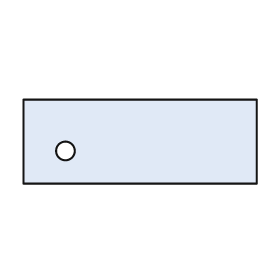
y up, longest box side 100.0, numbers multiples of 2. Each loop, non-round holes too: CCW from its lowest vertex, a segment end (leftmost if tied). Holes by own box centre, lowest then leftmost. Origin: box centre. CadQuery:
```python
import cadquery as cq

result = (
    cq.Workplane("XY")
    .moveTo(-50.0, -18.0)
    .lineTo(50.0, -18.0)
    .lineTo(50.0, 18.0)
    .lineTo(-50.0, 18.0)
    .close()
    .moveTo(-32.0, -4.0)
    .circle(4.0)
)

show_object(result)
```